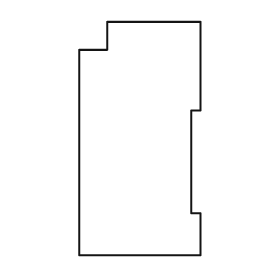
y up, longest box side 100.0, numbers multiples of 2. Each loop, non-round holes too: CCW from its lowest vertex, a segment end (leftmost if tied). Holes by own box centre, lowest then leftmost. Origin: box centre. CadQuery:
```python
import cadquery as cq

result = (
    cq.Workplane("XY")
    .moveTo(-26.0, -50.0)
    .lineTo(26.0, -50.0)
    .lineTo(26.0, -32.0)
    .lineTo(22.0, -32.0)
    .lineTo(22.0, 12.0)
    .lineTo(26.0, 12.0)
    .lineTo(26.0, 50.0)
    .lineTo(-14.0, 50.0)
    .lineTo(-14.0, 38.0)
    .lineTo(-26.0, 38.0)
    .close()
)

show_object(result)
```